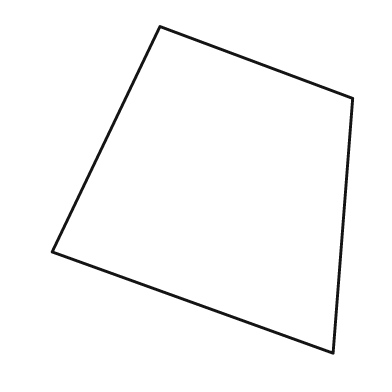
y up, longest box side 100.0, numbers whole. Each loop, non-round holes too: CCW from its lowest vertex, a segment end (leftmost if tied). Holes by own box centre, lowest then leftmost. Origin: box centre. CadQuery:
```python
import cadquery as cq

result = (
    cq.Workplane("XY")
    .moveTo(40.0, -50.0)
    .lineTo(46.0, 28.0)
    .lineTo(-13.0, 50.0)
    .lineTo(-46.0, -19.0)
    .close()
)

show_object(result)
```